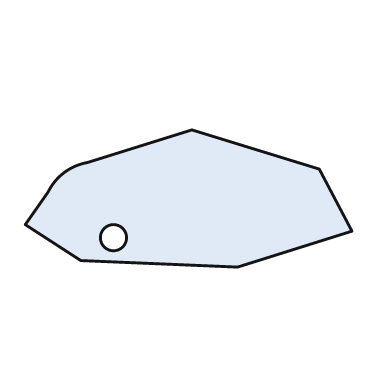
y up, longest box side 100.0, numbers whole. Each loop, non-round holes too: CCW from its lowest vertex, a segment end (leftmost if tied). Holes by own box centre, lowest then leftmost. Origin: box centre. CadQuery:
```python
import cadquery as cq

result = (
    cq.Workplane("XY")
    .moveTo(15.0, -21.0)
    .lineTo(50.0, -10.0)
    .lineTo(40.0, 9.0)
    .lineTo(1.0, 21.0)
    .lineTo(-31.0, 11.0)
    .threePointArc((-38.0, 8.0), (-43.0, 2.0))
    .lineTo(-50.0, -8.0)
    .lineTo(-33.0, -19.0)
    .close()
    .moveTo(-23.0, -12.0)
    .circle(4.0)
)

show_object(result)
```